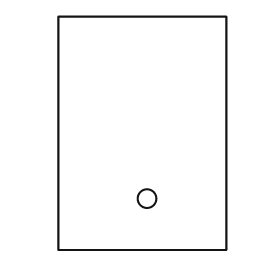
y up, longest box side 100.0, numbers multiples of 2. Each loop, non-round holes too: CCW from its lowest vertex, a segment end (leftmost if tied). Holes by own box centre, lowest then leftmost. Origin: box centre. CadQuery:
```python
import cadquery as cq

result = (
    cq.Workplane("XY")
    .moveTo(-36.0, -50.0)
    .lineTo(36.0, -50.0)
    .lineTo(36.0, 50.0)
    .lineTo(-36.0, 50.0)
    .close()
    .moveTo(2.0, -28.0)
    .circle(4.0)
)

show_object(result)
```